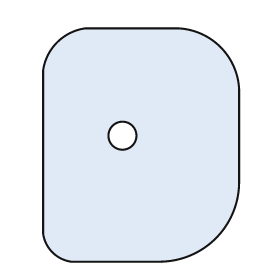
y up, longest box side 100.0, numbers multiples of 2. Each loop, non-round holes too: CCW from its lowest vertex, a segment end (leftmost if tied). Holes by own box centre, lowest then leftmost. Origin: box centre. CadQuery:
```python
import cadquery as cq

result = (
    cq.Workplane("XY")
    .moveTo(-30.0, -50.0)
    .lineTo(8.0, -50.0)
    .threePointArc((32.0, -40.0), (42.0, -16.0))
    .lineTo(42.0, 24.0)
    .threePointArc((34.0, 42.0), (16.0, 50.0))
    .lineTo(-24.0, 50.0)
    .threePointArc((-36.0, 44.0), (-42.0, 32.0))
    .lineTo(-42.0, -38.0)
    .threePointArc((-38.0, -46.0), (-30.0, -50.0))
    .close()
    .moveTo(-8.0, 4.0)
    .circle(6.0)
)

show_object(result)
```